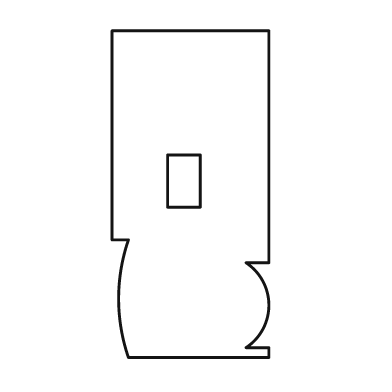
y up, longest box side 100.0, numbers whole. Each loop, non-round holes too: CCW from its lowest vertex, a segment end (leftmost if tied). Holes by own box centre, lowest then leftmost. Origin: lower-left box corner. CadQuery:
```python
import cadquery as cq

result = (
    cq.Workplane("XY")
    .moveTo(5.0, 0.0)
    .lineTo(48.0, 0.0)
    .lineTo(48.0, 3.0)
    .lineTo(41.0, 3.0)
    .threePointArc((48.0, 16.0), (41.0, 29.0))
    .lineTo(48.0, 29.0)
    .lineTo(48.0, 100.0)
    .lineTo(0.0, 100.0)
    .lineTo(0.0, 36.0)
    .lineTo(5.0, 36.0)
    .threePointArc((2.0, 18.0), (5.0, 0.0))
    .close()
    .moveTo(17.0, 46.0)
    .lineTo(27.0, 46.0)
    .lineTo(27.0, 62.0)
    .lineTo(17.0, 62.0)
    .close()
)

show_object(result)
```